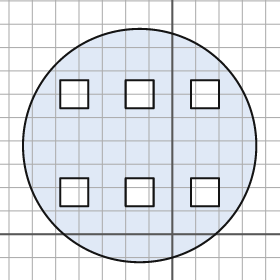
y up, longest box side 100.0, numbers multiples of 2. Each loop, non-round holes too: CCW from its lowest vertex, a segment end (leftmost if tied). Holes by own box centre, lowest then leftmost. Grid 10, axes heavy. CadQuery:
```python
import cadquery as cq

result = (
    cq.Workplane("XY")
    .moveTo(-14.0, 38.0)
    .circle(50.0)
    .moveTo(-48.0, 12.0)
    .lineTo(-36.0, 12.0)
    .lineTo(-36.0, 24.0)
    .lineTo(-48.0, 24.0)
    .close()
    .moveTo(-20.0, 12.0)
    .lineTo(-8.0, 12.0)
    .lineTo(-8.0, 24.0)
    .lineTo(-20.0, 24.0)
    .close()
    .moveTo(8.0, 12.0)
    .lineTo(20.0, 12.0)
    .lineTo(20.0, 24.0)
    .lineTo(8.0, 24.0)
    .close()
    .moveTo(-48.0, 54.0)
    .lineTo(-36.0, 54.0)
    .lineTo(-36.0, 66.0)
    .lineTo(-48.0, 66.0)
    .close()
    .moveTo(-20.0, 54.0)
    .lineTo(-8.0, 54.0)
    .lineTo(-8.0, 66.0)
    .lineTo(-20.0, 66.0)
    .close()
    .moveTo(8.0, 54.0)
    .lineTo(20.0, 54.0)
    .lineTo(20.0, 66.0)
    .lineTo(8.0, 66.0)
    .close()
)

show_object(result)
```